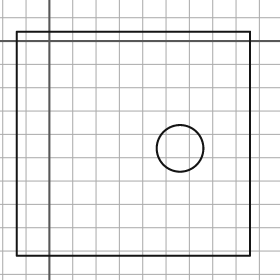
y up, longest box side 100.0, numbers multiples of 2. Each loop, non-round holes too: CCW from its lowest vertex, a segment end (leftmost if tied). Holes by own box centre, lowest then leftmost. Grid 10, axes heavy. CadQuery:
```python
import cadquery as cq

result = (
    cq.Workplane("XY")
    .moveTo(-14.0, -92.0)
    .lineTo(86.0, -92.0)
    .lineTo(86.0, 4.0)
    .lineTo(-14.0, 4.0)
    .close()
    .moveTo(56.0, -46.0)
    .circle(10.0)
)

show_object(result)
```